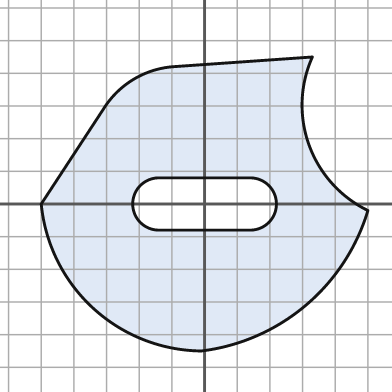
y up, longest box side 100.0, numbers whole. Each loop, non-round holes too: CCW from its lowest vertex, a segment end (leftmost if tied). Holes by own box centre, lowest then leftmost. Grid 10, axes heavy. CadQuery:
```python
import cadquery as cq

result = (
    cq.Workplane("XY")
    .moveTo(-1.0, -45.0)
    .threePointArc((31.0, -31.0), (50.0, -2.0))
    .threePointArc((32.0, 18.0), (33.0, 45.0))
    .lineTo(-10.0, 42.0)
    .threePointArc((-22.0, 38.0), (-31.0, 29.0))
    .lineTo(-50.0, 0.0)
    .threePointArc((-34.0, -32.0), (-1.0, -45.0))
    .close()
    .moveTo(-14.0, -8.0)
    .lineTo(14.0, -8.0)
    .threePointArc((22.0, 0.0), (14.0, 8.0))
    .lineTo(-14.0, 8.0)
    .threePointArc((-22.0, 0.0), (-14.0, -8.0))
    .close()
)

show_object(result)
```